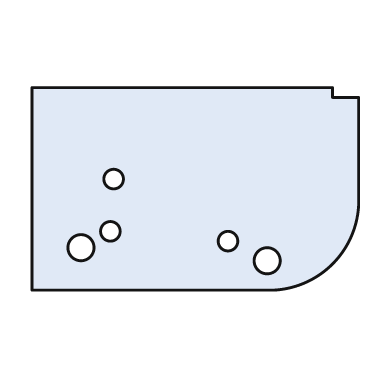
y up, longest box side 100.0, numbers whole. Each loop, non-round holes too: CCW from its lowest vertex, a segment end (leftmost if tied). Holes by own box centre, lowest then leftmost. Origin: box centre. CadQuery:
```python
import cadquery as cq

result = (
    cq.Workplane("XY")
    .moveTo(-50.0, -31.0)
    .lineTo(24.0, -31.0)
    .threePointArc((42.0, -23.0), (50.0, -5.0))
    .lineTo(50.0, 28.0)
    .lineTo(42.0, 28.0)
    .lineTo(42.0, 31.0)
    .lineTo(-50.0, 31.0)
    .close()
    .moveTo(22.0, -22.0)
    .circle(4.0)
    .moveTo(-35.0, -18.0)
    .circle(4.0)
    .moveTo(10.0, -16.0)
    .circle(3.0)
    .moveTo(-26.0, -13.0)
    .circle(3.0)
    .moveTo(-25.0, 3.0)
    .circle(3.0)
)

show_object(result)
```